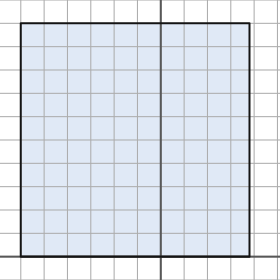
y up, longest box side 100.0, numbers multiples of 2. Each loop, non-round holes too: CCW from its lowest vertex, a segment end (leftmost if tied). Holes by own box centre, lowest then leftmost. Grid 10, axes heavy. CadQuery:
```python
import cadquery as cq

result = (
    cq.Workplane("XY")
    .moveTo(-60.0, 0.0)
    .lineTo(38.0, 0.0)
    .lineTo(38.0, 100.0)
    .lineTo(-60.0, 100.0)
    .close()
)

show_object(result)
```